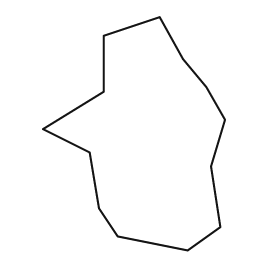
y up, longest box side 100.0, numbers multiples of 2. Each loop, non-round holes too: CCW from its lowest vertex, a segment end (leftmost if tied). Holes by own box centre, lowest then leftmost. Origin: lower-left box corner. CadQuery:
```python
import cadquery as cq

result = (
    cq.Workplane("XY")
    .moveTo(62.0, 0.0)
    .lineTo(76.0, 10.0)
    .lineTo(72.0, 36.0)
    .lineTo(78.0, 56.0)
    .lineTo(70.0, 70.0)
    .lineTo(60.0, 82.0)
    .lineTo(50.0, 100.0)
    .lineTo(26.0, 92.0)
    .lineTo(26.0, 68.0)
    .lineTo(0.0, 52.0)
    .lineTo(20.0, 42.0)
    .lineTo(24.0, 18.0)
    .lineTo(32.0, 6.0)
    .close()
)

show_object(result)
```